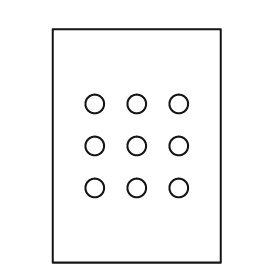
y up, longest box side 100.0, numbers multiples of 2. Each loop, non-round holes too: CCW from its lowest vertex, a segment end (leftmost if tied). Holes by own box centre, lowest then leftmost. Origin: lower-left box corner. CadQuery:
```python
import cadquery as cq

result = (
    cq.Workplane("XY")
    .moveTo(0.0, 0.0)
    .lineTo(72.0, 0.0)
    .lineTo(72.0, 100.0)
    .lineTo(0.0, 100.0)
    .close()
    .moveTo(18.0, 32.0)
    .circle(4.0)
    .moveTo(36.0, 32.0)
    .circle(4.0)
    .moveTo(54.0, 32.0)
    .circle(4.0)
    .moveTo(18.0, 50.0)
    .circle(4.0)
    .moveTo(36.0, 50.0)
    .circle(4.0)
    .moveTo(54.0, 50.0)
    .circle(4.0)
    .moveTo(18.0, 68.0)
    .circle(4.0)
    .moveTo(36.0, 68.0)
    .circle(4.0)
    .moveTo(54.0, 68.0)
    .circle(4.0)
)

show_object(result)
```